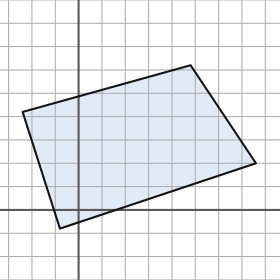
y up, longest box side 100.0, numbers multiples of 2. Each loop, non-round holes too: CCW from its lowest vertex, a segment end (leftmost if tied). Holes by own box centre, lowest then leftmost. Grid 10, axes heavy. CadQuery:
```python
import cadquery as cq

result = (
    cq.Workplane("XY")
    .moveTo(-8.0, -8.0)
    .lineTo(76.0, 20.0)
    .lineTo(48.0, 62.0)
    .lineTo(-24.0, 42.0)
    .close()
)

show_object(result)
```